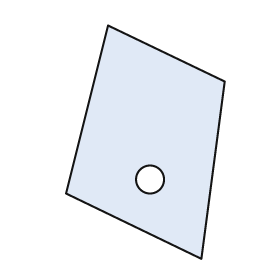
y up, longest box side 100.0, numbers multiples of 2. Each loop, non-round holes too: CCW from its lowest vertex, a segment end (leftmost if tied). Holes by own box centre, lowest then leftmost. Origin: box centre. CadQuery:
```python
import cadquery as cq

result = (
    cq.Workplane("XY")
    .moveTo(24.0, -50.0)
    .lineTo(34.0, 26.0)
    .lineTo(-16.0, 50.0)
    .lineTo(-34.0, -22.0)
    .close()
    .moveTo(2.0, -16.0)
    .circle(6.0)
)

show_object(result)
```